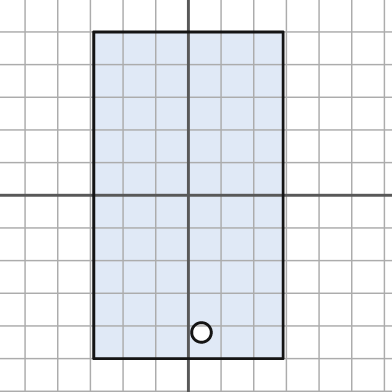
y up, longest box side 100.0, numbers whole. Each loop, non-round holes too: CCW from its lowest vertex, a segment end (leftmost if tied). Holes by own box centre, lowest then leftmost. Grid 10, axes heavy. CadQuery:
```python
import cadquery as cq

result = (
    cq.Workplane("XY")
    .moveTo(-29.0, -50.0)
    .lineTo(29.0, -50.0)
    .lineTo(29.0, 50.0)
    .lineTo(-29.0, 50.0)
    .close()
    .moveTo(4.0, -42.0)
    .circle(3.0)
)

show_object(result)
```